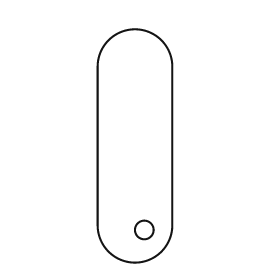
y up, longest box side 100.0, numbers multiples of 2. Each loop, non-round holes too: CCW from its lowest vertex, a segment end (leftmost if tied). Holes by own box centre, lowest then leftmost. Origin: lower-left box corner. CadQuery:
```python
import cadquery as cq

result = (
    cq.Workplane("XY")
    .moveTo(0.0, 16.0)
    .threePointArc((16.0, 0.0), (32.0, 16.0))
    .lineTo(32.0, 84.0)
    .threePointArc((16.0, 100.0), (0.0, 84.0))
    .close()
    .moveTo(20.0, 14.0)
    .circle(4.0)
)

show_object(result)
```